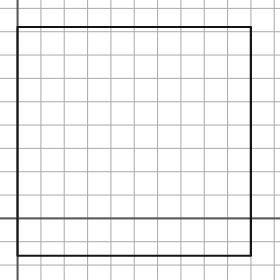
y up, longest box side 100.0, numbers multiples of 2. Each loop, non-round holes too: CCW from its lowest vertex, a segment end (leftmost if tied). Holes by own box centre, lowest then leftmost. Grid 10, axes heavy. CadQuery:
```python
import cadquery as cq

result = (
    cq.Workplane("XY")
    .moveTo(0.0, -16.0)
    .lineTo(100.0, -16.0)
    .lineTo(100.0, 82.0)
    .lineTo(0.0, 82.0)
    .close()
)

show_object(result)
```